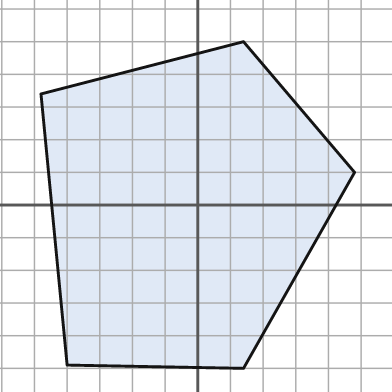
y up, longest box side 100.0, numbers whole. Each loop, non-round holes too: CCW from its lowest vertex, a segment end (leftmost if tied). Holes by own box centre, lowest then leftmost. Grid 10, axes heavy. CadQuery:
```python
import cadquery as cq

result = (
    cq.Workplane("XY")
    .moveTo(14.0, -50.0)
    .lineTo(48.0, 10.0)
    .lineTo(14.0, 50.0)
    .lineTo(-48.0, 34.0)
    .lineTo(-40.0, -49.0)
    .close()
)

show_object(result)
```